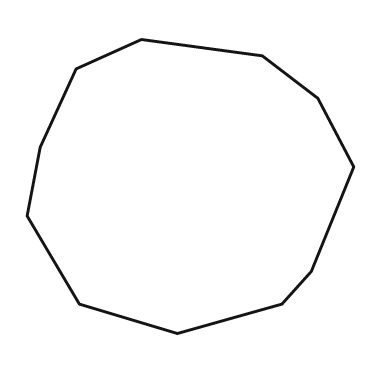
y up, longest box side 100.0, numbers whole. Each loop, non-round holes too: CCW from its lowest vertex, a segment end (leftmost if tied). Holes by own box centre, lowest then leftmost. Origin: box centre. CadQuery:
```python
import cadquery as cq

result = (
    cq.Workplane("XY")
    .moveTo(-4.0, -45.0)
    .lineTo(28.0, -36.0)
    .lineTo(37.0, -26.0)
    .lineTo(50.0, 6.0)
    .lineTo(39.0, 27.0)
    .lineTo(22.0, 40.0)
    .lineTo(-15.0, 45.0)
    .lineTo(-35.0, 36.0)
    .lineTo(-46.0, 12.0)
    .lineTo(-50.0, -9.0)
    .lineTo(-34.0, -36.0)
    .close()
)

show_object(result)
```